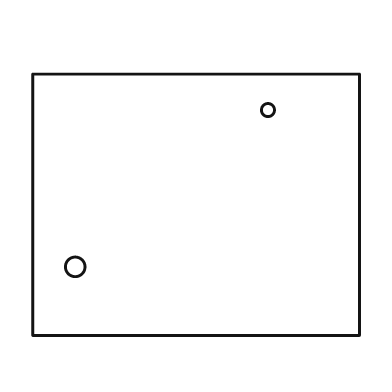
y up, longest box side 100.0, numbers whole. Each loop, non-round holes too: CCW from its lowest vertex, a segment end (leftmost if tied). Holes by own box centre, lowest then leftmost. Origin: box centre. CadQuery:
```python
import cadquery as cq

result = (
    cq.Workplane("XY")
    .moveTo(-50.0, -40.0)
    .lineTo(50.0, -40.0)
    .lineTo(50.0, 40.0)
    .lineTo(-50.0, 40.0)
    .close()
    .moveTo(-37.0, -19.0)
    .circle(3.0)
    .moveTo(22.0, 29.0)
    .circle(2.0)
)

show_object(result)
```